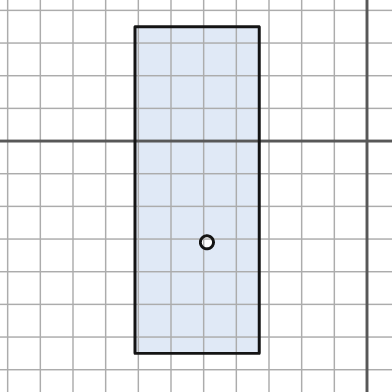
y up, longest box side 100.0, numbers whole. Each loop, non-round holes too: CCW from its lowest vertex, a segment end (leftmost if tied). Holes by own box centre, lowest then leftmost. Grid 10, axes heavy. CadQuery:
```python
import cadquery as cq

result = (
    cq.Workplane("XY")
    .moveTo(-71.0, -65.0)
    .lineTo(-33.0, -65.0)
    .lineTo(-33.0, 35.0)
    .lineTo(-71.0, 35.0)
    .close()
    .moveTo(-49.0, -31.0)
    .circle(2.0)
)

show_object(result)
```